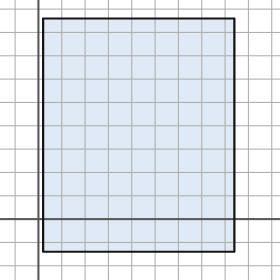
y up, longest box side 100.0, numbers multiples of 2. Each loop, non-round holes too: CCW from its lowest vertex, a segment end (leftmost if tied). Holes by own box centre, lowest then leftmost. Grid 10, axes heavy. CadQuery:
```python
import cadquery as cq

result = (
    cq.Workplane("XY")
    .moveTo(2.0, -14.0)
    .lineTo(84.0, -14.0)
    .lineTo(84.0, 86.0)
    .lineTo(2.0, 86.0)
    .close()
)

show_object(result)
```